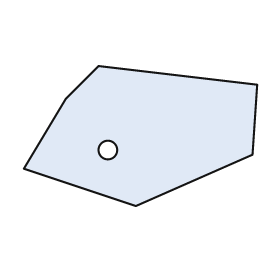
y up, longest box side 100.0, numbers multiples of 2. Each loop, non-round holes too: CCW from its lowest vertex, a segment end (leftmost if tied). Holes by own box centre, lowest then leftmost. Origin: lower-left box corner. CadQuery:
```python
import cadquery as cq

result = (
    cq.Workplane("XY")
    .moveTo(48.0, 0.0)
    .lineTo(98.0, 22.0)
    .lineTo(100.0, 52.0)
    .lineTo(32.0, 60.0)
    .lineTo(18.0, 46.0)
    .lineTo(0.0, 16.0)
    .close()
    .moveTo(36.0, 24.0)
    .circle(4.0)
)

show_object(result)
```